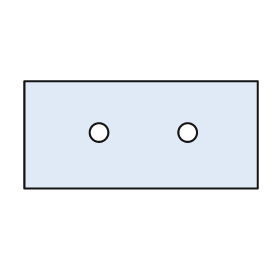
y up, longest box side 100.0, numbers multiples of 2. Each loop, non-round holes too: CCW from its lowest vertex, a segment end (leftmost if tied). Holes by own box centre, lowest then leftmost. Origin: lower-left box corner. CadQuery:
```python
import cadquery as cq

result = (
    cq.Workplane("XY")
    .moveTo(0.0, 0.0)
    .lineTo(100.0, 0.0)
    .lineTo(100.0, 46.0)
    .lineTo(0.0, 46.0)
    .close()
    .moveTo(32.0, 24.0)
    .circle(4.0)
    .moveTo(70.0, 24.0)
    .circle(4.0)
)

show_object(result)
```